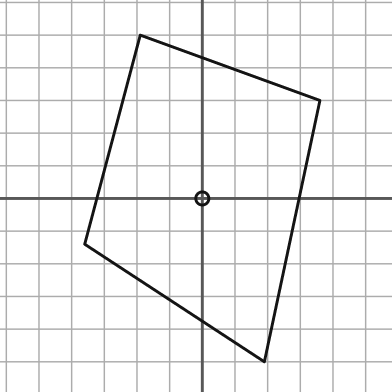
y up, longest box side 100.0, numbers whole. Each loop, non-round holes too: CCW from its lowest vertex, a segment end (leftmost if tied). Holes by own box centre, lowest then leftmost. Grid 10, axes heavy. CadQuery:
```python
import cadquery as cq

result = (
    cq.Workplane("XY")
    .moveTo(19.0, -50.0)
    .lineTo(36.0, 30.0)
    .lineTo(-19.0, 50.0)
    .lineTo(-36.0, -14.0)
    .close()
    .moveTo(0.0, 0.0)
    .circle(2.0)
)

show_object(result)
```